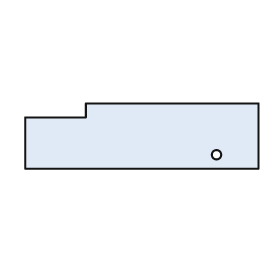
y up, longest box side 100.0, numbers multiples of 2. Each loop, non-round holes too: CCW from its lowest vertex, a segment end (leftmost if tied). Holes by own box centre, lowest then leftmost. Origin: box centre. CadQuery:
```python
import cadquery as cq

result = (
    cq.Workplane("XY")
    .moveTo(-50.0, -14.0)
    .lineTo(50.0, -14.0)
    .lineTo(50.0, 14.0)
    .lineTo(-24.0, 14.0)
    .lineTo(-24.0, 8.0)
    .lineTo(-50.0, 8.0)
    .close()
    .moveTo(32.0, -8.0)
    .circle(2.0)
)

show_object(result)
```